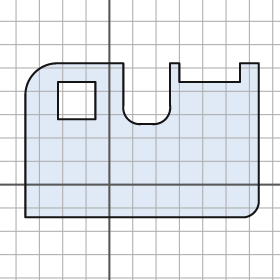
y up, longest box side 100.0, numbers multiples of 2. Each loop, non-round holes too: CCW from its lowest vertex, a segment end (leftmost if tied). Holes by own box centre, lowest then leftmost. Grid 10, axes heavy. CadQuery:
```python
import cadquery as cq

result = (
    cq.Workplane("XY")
    .moveTo(-36.0, -14.0)
    .lineTo(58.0, -14.0)
    .threePointArc((62.0, -12.0), (64.0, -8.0))
    .lineTo(64.0, 52.0)
    .lineTo(56.0, 52.0)
    .lineTo(56.0, 44.0)
    .lineTo(30.0, 44.0)
    .lineTo(30.0, 52.0)
    .lineTo(26.0, 52.0)
    .lineTo(26.0, 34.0)
    .threePointArc((24.0, 28.0), (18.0, 26.0))
    .lineTo(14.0, 26.0)
    .threePointArc((8.0, 28.0), (6.0, 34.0))
    .lineTo(6.0, 52.0)
    .lineTo(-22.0, 52.0)
    .threePointArc((-32.0, 48.0), (-36.0, 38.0))
    .close()
    .moveTo(-22.0, 28.0)
    .lineTo(-6.0, 28.0)
    .lineTo(-6.0, 44.0)
    .lineTo(-22.0, 44.0)
    .close()
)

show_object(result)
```